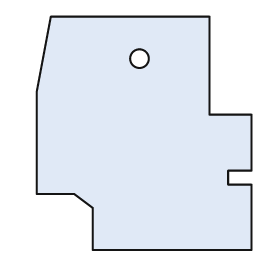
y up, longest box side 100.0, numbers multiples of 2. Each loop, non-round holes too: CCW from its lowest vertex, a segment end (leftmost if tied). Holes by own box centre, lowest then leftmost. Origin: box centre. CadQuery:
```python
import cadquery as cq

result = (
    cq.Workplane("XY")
    .moveTo(-22.0, -50.0)
    .lineTo(46.0, -50.0)
    .lineTo(46.0, -22.0)
    .lineTo(36.0, -22.0)
    .lineTo(36.0, -16.0)
    .lineTo(46.0, -16.0)
    .lineTo(46.0, 8.0)
    .lineTo(28.0, 8.0)
    .lineTo(28.0, 50.0)
    .lineTo(-40.0, 50.0)
    .lineTo(-46.0, 18.0)
    .lineTo(-46.0, -26.0)
    .lineTo(-30.0, -26.0)
    .lineTo(-22.0, -32.0)
    .close()
    .moveTo(-2.0, 32.0)
    .circle(4.0)
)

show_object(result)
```